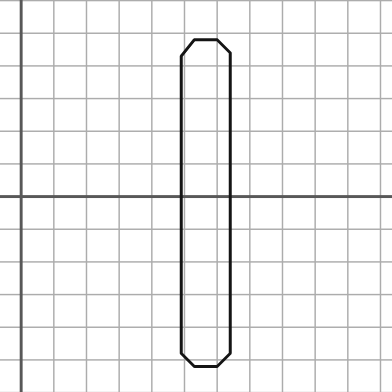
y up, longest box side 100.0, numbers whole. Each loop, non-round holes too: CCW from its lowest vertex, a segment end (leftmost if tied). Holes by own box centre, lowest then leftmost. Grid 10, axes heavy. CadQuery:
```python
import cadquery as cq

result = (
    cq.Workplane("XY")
    .moveTo(53.0, -52.0)
    .lineTo(60.0, -52.0)
    .lineTo(64.0, -48.0)
    .lineTo(64.0, 44.0)
    .lineTo(60.0, 48.0)
    .lineTo(53.0, 48.0)
    .lineTo(49.0, 43.0)
    .lineTo(49.0, -48.0)
    .close()
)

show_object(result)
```